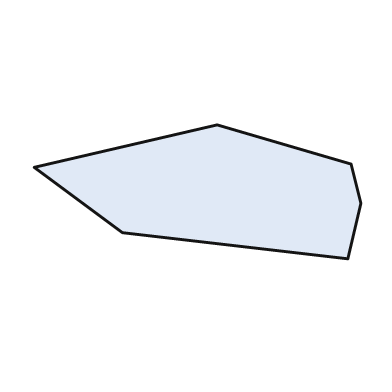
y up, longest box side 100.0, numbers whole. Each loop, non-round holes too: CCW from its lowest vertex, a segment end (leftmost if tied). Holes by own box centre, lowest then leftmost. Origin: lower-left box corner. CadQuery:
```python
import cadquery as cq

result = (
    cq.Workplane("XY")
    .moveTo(96.0, 0.0)
    .lineTo(100.0, 17.0)
    .lineTo(97.0, 29.0)
    .lineTo(56.0, 41.0)
    .lineTo(0.0, 28.0)
    .lineTo(27.0, 8.0)
    .close()
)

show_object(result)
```